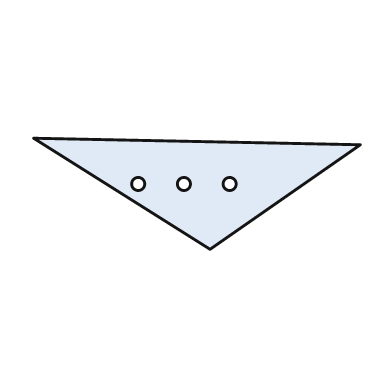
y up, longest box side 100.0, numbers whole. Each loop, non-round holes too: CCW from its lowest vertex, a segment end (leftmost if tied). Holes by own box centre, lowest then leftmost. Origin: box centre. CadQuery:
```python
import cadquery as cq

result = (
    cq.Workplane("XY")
    .moveTo(4.0, -17.0)
    .lineTo(50.0, 15.0)
    .lineTo(-50.0, 17.0)
    .close()
    .moveTo(-18.0, 3.0)
    .circle(2.0)
    .moveTo(-4.0, 3.0)
    .circle(2.0)
    .moveTo(10.0, 3.0)
    .circle(2.0)
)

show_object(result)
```